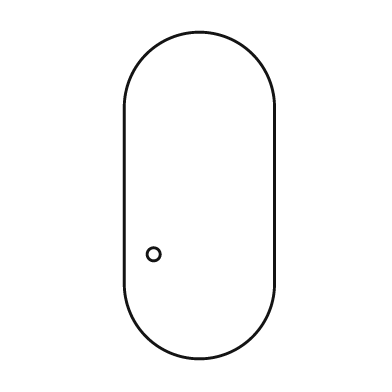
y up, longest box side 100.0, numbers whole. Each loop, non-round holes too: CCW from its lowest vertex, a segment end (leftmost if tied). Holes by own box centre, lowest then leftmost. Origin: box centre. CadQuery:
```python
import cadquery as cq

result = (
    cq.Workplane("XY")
    .moveTo(-23.0, -27.0)
    .threePointArc((0.0, -50.0), (23.0, -27.0))
    .lineTo(23.0, 27.0)
    .threePointArc((0.0, 50.0), (-23.0, 27.0))
    .close()
    .moveTo(-14.0, -18.0)
    .circle(2.0)
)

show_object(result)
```